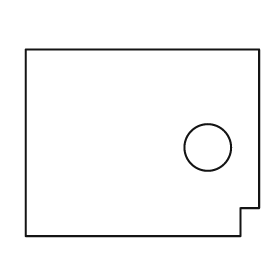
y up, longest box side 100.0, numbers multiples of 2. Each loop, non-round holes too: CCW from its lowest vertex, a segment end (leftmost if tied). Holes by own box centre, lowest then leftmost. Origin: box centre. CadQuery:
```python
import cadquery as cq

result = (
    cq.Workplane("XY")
    .moveTo(-50.0, -40.0)
    .lineTo(42.0, -40.0)
    .lineTo(42.0, -28.0)
    .lineTo(50.0, -28.0)
    .lineTo(50.0, 40.0)
    .lineTo(-50.0, 40.0)
    .close()
    .moveTo(28.0, -2.0)
    .circle(10.0)
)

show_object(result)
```